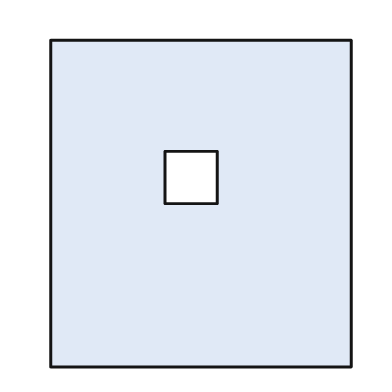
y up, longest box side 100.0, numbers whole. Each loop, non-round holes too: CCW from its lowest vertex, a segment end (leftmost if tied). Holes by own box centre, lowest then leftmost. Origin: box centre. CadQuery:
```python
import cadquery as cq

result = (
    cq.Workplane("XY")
    .moveTo(-46.0, -50.0)
    .lineTo(46.0, -50.0)
    .lineTo(46.0, 50.0)
    .lineTo(-46.0, 50.0)
    .close()
    .moveTo(-11.0, 0.0)
    .lineTo(5.0, 0.0)
    .lineTo(5.0, 16.0)
    .lineTo(-11.0, 16.0)
    .close()
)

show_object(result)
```